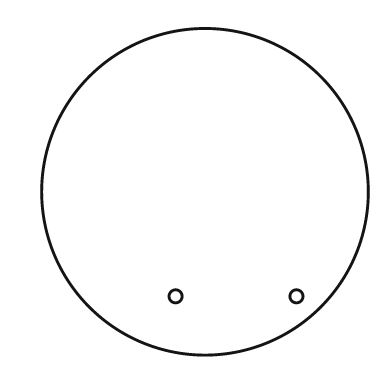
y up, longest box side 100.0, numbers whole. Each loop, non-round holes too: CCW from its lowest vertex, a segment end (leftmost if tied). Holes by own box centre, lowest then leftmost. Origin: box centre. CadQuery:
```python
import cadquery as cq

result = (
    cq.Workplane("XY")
    .moveTo(0.0, 0.0)
    .circle(50.0)
    .moveTo(-9.0, -32.0)
    .circle(2.0)
    .moveTo(28.0, -32.0)
    .circle(2.0)
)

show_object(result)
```